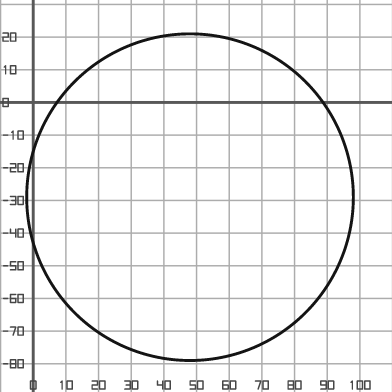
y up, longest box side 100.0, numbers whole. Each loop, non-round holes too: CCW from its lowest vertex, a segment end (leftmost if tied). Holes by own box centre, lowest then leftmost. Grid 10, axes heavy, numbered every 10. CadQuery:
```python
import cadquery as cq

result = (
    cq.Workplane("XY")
    .moveTo(48.0, -29.0)
    .circle(50.0)
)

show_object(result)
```